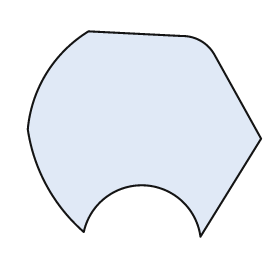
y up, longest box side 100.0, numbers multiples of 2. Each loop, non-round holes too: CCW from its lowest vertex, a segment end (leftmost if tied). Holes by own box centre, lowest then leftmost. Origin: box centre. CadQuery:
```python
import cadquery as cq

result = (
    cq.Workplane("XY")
    .moveTo(24.0, -44.0)
    .lineTo(50.0, -2.0)
    .lineTo(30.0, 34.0)
    .threePointArc((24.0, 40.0), (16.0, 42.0))
    .lineTo(-24.0, 44.0)
    .threePointArc((-42.0, 26.0), (-50.0, 2.0))
    .threePointArc((-42.0, -22.0), (-26.0, -42.0))
    .threePointArc((0.0, -22.0), (24.0, -44.0))
    .close()
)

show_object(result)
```